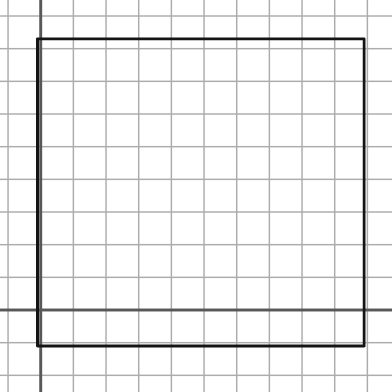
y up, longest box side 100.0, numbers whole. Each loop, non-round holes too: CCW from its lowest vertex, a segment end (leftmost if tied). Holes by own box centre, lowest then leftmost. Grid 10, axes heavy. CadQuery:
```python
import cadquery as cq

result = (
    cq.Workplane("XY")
    .moveTo(-1.0, -11.0)
    .lineTo(99.0, -11.0)
    .lineTo(99.0, 83.0)
    .lineTo(-1.0, 83.0)
    .close()
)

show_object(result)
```